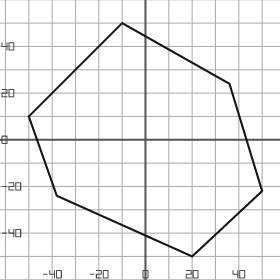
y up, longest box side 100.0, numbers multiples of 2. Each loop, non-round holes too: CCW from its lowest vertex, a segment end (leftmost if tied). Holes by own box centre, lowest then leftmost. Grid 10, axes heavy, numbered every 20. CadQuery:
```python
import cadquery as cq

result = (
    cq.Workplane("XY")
    .moveTo(20.0, -50.0)
    .lineTo(50.0, -22.0)
    .lineTo(36.0, 24.0)
    .lineTo(-10.0, 50.0)
    .lineTo(-50.0, 10.0)
    .lineTo(-38.0, -24.0)
    .close()
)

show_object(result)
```